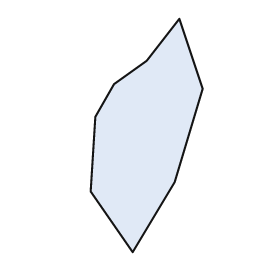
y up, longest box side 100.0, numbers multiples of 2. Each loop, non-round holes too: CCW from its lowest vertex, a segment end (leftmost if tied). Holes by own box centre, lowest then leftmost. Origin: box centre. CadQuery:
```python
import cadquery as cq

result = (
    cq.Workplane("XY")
    .moveTo(-6.0, -50.0)
    .lineTo(12.0, -20.0)
    .lineTo(24.0, 20.0)
    .lineTo(14.0, 50.0)
    .lineTo(0.0, 32.0)
    .lineTo(-14.0, 22.0)
    .lineTo(-22.0, 8.0)
    .lineTo(-24.0, -24.0)
    .close()
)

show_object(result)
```